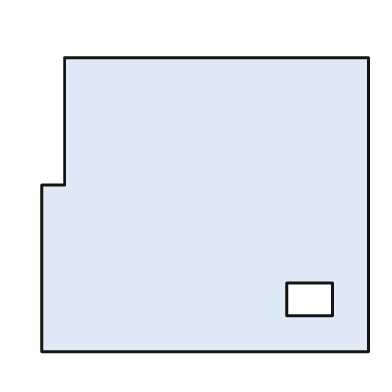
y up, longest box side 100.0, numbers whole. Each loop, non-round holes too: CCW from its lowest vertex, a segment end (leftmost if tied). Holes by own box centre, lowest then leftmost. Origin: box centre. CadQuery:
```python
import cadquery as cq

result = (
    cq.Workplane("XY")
    .moveTo(-50.0, -45.0)
    .lineTo(50.0, -45.0)
    .lineTo(50.0, 45.0)
    .lineTo(-43.0, 45.0)
    .lineTo(-43.0, 6.0)
    .lineTo(-50.0, 6.0)
    .close()
    .moveTo(25.0, -34.0)
    .lineTo(39.0, -34.0)
    .lineTo(39.0, -24.0)
    .lineTo(25.0, -24.0)
    .close()
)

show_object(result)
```